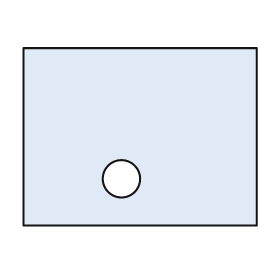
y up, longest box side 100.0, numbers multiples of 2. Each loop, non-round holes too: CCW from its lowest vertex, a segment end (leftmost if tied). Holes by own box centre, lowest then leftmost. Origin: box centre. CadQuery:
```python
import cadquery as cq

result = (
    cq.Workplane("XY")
    .moveTo(-50.0, -38.0)
    .lineTo(50.0, -38.0)
    .lineTo(50.0, 38.0)
    .lineTo(-50.0, 38.0)
    .close()
    .moveTo(-8.0, -18.0)
    .circle(8.0)
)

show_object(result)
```